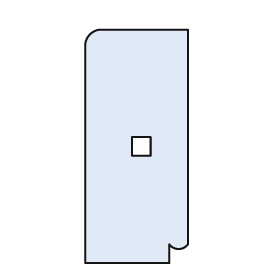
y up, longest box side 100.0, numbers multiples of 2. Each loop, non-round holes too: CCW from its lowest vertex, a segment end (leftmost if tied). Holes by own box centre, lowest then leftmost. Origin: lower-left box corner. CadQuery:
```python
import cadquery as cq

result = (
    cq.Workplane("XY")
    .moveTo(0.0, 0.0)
    .lineTo(36.0, 0.0)
    .lineTo(36.0, 8.0)
    .threePointArc((40.0, 6.0), (44.0, 8.0))
    .lineTo(44.0, 100.0)
    .lineTo(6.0, 100.0)
    .threePointArc((2.0, 98.0), (0.0, 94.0))
    .close()
    .moveTo(20.0, 46.0)
    .lineTo(28.0, 46.0)
    .lineTo(28.0, 54.0)
    .lineTo(20.0, 54.0)
    .close()
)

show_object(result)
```